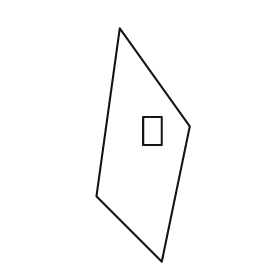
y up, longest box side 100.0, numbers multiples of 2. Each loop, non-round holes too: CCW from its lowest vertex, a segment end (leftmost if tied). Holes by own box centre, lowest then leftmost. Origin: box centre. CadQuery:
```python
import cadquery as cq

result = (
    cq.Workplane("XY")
    .moveTo(8.0, -50.0)
    .lineTo(20.0, 8.0)
    .lineTo(-10.0, 50.0)
    .lineTo(-20.0, -22.0)
    .close()
    .moveTo(0.0, 0.0)
    .lineTo(8.0, 0.0)
    .lineTo(8.0, 12.0)
    .lineTo(0.0, 12.0)
    .close()
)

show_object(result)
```